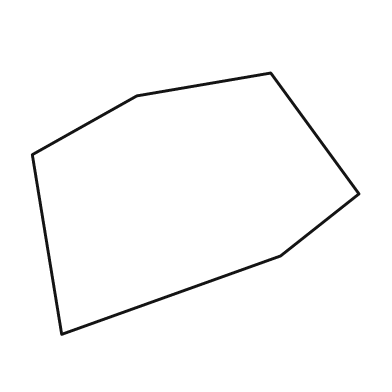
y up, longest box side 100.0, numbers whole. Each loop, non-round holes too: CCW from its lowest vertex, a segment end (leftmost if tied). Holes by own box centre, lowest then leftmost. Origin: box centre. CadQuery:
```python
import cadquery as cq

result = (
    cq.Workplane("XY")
    .moveTo(-41.0, -40.0)
    .lineTo(26.0, -16.0)
    .lineTo(50.0, 3.0)
    .lineTo(23.0, 40.0)
    .lineTo(-18.0, 33.0)
    .lineTo(-50.0, 15.0)
    .close()
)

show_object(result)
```